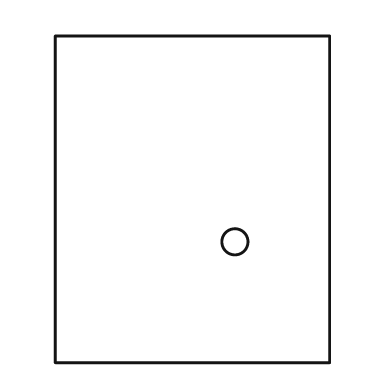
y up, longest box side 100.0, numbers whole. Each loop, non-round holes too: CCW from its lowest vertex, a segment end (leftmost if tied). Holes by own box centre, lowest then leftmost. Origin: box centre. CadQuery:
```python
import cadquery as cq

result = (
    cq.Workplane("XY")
    .moveTo(-42.0, -50.0)
    .lineTo(42.0, -50.0)
    .lineTo(42.0, 50.0)
    .lineTo(-42.0, 50.0)
    .close()
    .moveTo(13.0, -13.0)
    .circle(4.0)
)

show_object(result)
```